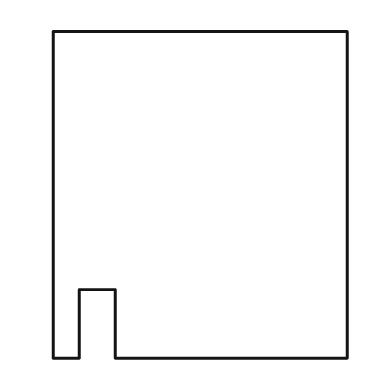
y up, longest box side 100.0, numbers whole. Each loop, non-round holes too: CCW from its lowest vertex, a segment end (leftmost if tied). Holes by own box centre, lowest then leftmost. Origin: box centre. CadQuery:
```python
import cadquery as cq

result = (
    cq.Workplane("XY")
    .moveTo(-45.0, -50.0)
    .lineTo(-37.0, -50.0)
    .lineTo(-37.0, -29.0)
    .lineTo(-26.0, -29.0)
    .lineTo(-26.0, -50.0)
    .lineTo(45.0, -50.0)
    .lineTo(45.0, 50.0)
    .lineTo(-45.0, 50.0)
    .close()
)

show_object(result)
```